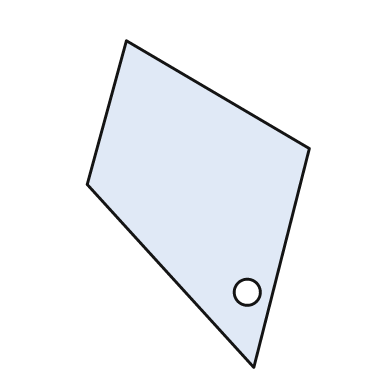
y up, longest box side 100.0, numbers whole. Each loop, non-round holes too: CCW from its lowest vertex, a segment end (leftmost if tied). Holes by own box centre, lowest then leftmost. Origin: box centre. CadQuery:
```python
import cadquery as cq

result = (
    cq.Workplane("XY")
    .moveTo(17.0, -50.0)
    .lineTo(34.0, 17.0)
    .lineTo(-22.0, 50.0)
    .lineTo(-34.0, 6.0)
    .close()
    .moveTo(15.0, -27.0)
    .circle(4.0)
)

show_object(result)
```